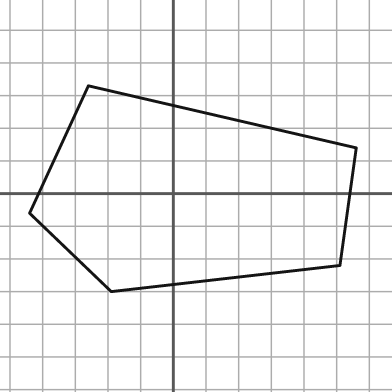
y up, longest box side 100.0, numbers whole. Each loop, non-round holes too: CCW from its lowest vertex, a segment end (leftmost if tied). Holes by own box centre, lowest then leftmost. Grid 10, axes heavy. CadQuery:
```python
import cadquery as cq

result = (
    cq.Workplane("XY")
    .moveTo(-19.0, -30.0)
    .lineTo(51.0, -22.0)
    .lineTo(56.0, 14.0)
    .lineTo(-26.0, 33.0)
    .lineTo(-44.0, -6.0)
    .close()
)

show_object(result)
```